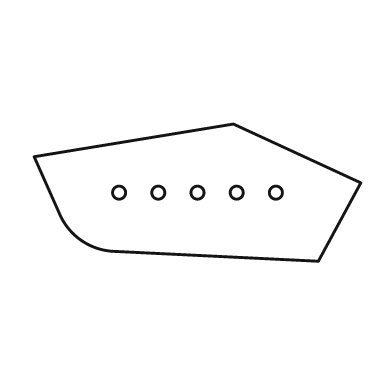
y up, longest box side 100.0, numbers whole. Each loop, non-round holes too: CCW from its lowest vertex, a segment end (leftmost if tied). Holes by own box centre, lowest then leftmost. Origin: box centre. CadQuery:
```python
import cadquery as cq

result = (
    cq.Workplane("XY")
    .moveTo(37.0, -21.0)
    .lineTo(50.0, 3.0)
    .lineTo(11.0, 21.0)
    .lineTo(-50.0, 11.0)
    .lineTo(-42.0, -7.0)
    .threePointArc((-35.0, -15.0), (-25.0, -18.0))
    .close()
    .moveTo(-24.0, 0.0)
    .circle(2.0)
    .moveTo(-12.0, 0.0)
    .circle(2.0)
    .moveTo(0.0, 0.0)
    .circle(2.0)
    .moveTo(12.0, 0.0)
    .circle(2.0)
    .moveTo(24.0, 0.0)
    .circle(2.0)
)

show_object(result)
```